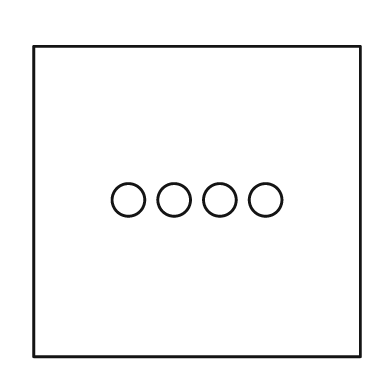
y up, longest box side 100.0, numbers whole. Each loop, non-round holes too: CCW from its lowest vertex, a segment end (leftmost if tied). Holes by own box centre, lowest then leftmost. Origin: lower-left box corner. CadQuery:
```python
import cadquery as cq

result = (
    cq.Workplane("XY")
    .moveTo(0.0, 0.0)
    .lineTo(100.0, 0.0)
    .lineTo(100.0, 95.0)
    .lineTo(0.0, 95.0)
    .close()
    .moveTo(29.0, 48.0)
    .circle(5.0)
    .moveTo(43.0, 48.0)
    .circle(5.0)
    .moveTo(57.0, 48.0)
    .circle(5.0)
    .moveTo(71.0, 48.0)
    .circle(5.0)
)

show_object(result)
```